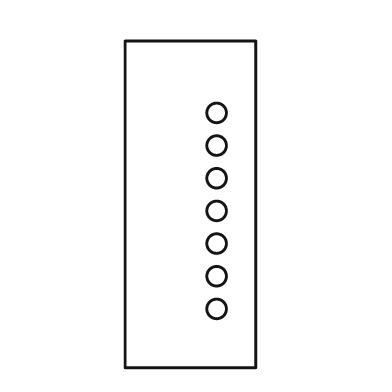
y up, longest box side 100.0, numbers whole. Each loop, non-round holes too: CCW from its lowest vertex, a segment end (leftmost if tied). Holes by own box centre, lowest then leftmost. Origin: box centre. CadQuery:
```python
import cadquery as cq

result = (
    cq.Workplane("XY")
    .moveTo(-20.0, -50.0)
    .lineTo(20.0, -50.0)
    .lineTo(20.0, 50.0)
    .lineTo(-20.0, 50.0)
    .close()
    .moveTo(8.0, -32.0)
    .circle(3.0)
    .moveTo(8.0, -22.0)
    .circle(3.0)
    .moveTo(8.0, -12.0)
    .circle(3.0)
    .moveTo(8.0, -2.0)
    .circle(3.0)
    .moveTo(8.0, 8.0)
    .circle(3.0)
    .moveTo(8.0, 18.0)
    .circle(3.0)
    .moveTo(8.0, 28.0)
    .circle(3.0)
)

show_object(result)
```